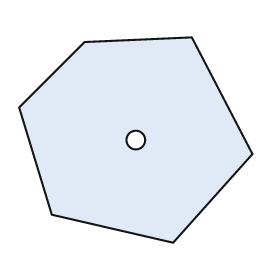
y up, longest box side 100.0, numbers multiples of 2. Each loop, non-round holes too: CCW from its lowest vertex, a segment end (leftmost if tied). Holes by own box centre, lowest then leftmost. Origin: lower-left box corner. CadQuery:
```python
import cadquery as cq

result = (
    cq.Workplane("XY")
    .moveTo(66.0, 0.0)
    .lineTo(100.0, 38.0)
    .lineTo(74.0, 88.0)
    .lineTo(28.0, 86.0)
    .lineTo(0.0, 58.0)
    .lineTo(14.0, 12.0)
    .close()
    .moveTo(50.0, 44.0)
    .circle(4.0)
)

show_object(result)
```